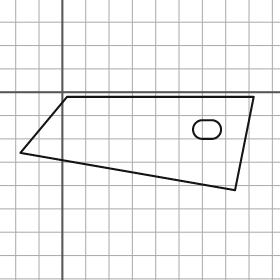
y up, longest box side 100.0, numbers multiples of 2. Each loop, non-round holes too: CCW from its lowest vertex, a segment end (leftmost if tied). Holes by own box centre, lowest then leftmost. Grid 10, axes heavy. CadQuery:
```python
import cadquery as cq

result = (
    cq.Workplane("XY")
    .moveTo(74.0, -42.0)
    .lineTo(82.0, -2.0)
    .lineTo(2.0, -2.0)
    .lineTo(-18.0, -26.0)
    .close()
    .moveTo(60.0, -20.0)
    .lineTo(64.0, -20.0)
    .threePointArc((68.0, -16.0), (64.0, -12.0))
    .lineTo(60.0, -12.0)
    .threePointArc((56.0, -16.0), (60.0, -20.0))
    .close()
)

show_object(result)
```